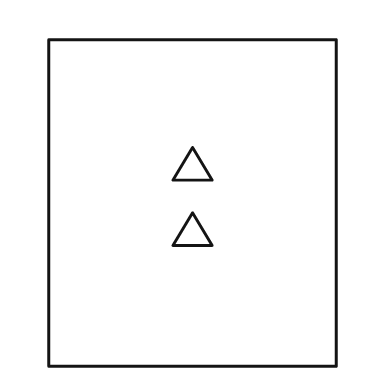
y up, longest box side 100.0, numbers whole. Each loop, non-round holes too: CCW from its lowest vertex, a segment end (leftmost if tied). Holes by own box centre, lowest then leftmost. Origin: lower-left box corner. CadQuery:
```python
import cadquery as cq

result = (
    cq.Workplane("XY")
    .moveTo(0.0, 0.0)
    .lineTo(88.0, 0.0)
    .lineTo(88.0, 100.0)
    .lineTo(0.0, 100.0)
    .close()
    .moveTo(38.0, 37.0)
    .lineTo(50.0, 37.0)
    .lineTo(44.0, 47.0)
    .close()
    .moveTo(38.0, 57.0)
    .lineTo(50.0, 57.0)
    .lineTo(44.0, 67.0)
    .close()
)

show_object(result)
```